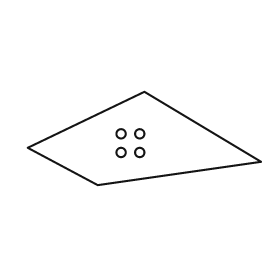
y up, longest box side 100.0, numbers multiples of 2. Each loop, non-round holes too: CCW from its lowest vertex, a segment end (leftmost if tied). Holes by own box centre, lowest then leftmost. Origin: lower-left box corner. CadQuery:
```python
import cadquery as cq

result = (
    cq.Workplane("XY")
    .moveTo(30.0, 0.0)
    .lineTo(100.0, 10.0)
    .lineTo(50.0, 40.0)
    .lineTo(0.0, 16.0)
    .close()
    .moveTo(40.0, 14.0)
    .circle(2.0)
    .moveTo(48.0, 14.0)
    .circle(2.0)
    .moveTo(40.0, 22.0)
    .circle(2.0)
    .moveTo(48.0, 22.0)
    .circle(2.0)
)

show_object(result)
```